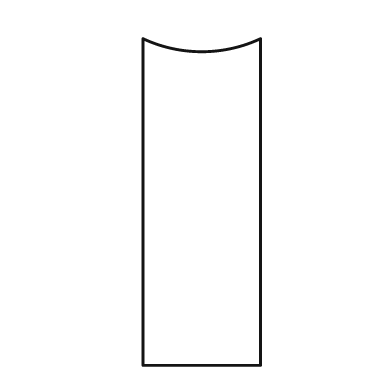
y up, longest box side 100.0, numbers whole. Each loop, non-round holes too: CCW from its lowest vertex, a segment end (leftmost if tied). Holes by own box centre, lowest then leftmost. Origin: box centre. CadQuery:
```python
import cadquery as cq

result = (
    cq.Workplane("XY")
    .moveTo(-18.0, -50.0)
    .lineTo(18.0, -50.0)
    .lineTo(18.0, 50.0)
    .threePointArc((0.0, 46.0), (-18.0, 50.0))
    .close()
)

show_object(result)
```